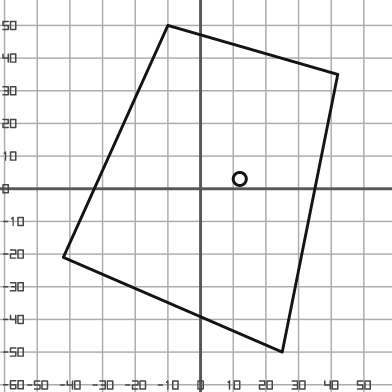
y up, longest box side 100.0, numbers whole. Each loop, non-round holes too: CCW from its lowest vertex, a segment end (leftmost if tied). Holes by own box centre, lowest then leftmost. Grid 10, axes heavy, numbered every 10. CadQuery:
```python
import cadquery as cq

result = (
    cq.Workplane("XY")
    .moveTo(25.0, -50.0)
    .lineTo(42.0, 35.0)
    .lineTo(-10.0, 50.0)
    .lineTo(-42.0, -21.0)
    .close()
    .moveTo(12.0, 3.0)
    .circle(2.0)
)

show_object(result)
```